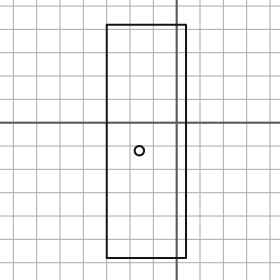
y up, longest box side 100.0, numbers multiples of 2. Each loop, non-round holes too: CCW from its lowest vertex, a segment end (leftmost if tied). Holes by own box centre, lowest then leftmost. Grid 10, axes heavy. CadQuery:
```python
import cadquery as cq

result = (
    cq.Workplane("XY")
    .moveTo(-30.0, -58.0)
    .lineTo(4.0, -58.0)
    .lineTo(4.0, 42.0)
    .lineTo(-30.0, 42.0)
    .close()
    .moveTo(-16.0, -12.0)
    .circle(2.0)
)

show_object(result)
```